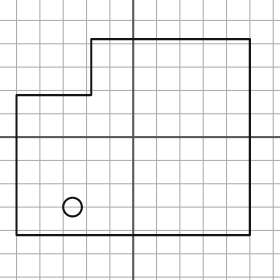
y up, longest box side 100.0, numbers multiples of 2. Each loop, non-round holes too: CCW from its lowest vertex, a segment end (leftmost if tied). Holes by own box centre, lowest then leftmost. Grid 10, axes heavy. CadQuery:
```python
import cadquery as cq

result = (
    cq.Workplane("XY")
    .moveTo(-50.0, -42.0)
    .lineTo(50.0, -42.0)
    .lineTo(50.0, 42.0)
    .lineTo(-18.0, 42.0)
    .lineTo(-18.0, 18.0)
    .lineTo(-50.0, 18.0)
    .close()
    .moveTo(-26.0, -30.0)
    .circle(4.0)
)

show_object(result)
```